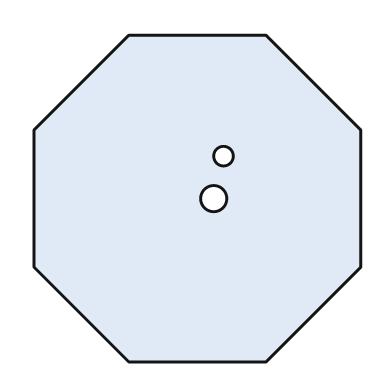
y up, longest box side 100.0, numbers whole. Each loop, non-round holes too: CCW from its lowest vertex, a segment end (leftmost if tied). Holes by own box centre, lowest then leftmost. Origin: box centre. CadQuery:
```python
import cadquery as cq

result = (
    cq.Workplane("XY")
    .moveTo(-21.0, -50.0)
    .lineTo(21.0, -50.0)
    .lineTo(50.0, -21.0)
    .lineTo(50.0, 21.0)
    .lineTo(21.0, 50.0)
    .lineTo(-21.0, 50.0)
    .lineTo(-50.0, 21.0)
    .lineTo(-50.0, -21.0)
    .close()
    .moveTo(5.0, 0.0)
    .circle(4.0)
    .moveTo(8.0, 13.0)
    .circle(3.0)
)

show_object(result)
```